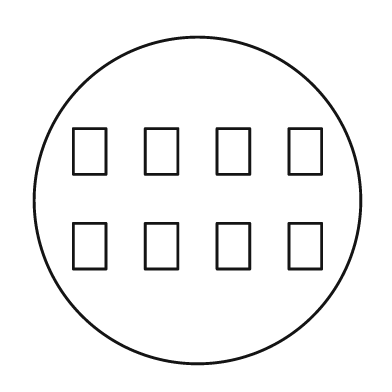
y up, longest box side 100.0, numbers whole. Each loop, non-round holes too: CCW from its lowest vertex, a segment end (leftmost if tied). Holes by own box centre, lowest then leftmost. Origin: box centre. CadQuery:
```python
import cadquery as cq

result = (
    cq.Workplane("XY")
    .moveTo(0.0, 0.0)
    .circle(50.0)
    .moveTo(-38.0, -21.0)
    .lineTo(-28.0, -21.0)
    .lineTo(-28.0, -7.0)
    .lineTo(-38.0, -7.0)
    .close()
    .moveTo(-16.0, -21.0)
    .lineTo(-6.0, -21.0)
    .lineTo(-6.0, -7.0)
    .lineTo(-16.0, -7.0)
    .close()
    .moveTo(6.0, -21.0)
    .lineTo(16.0, -21.0)
    .lineTo(16.0, -7.0)
    .lineTo(6.0, -7.0)
    .close()
    .moveTo(28.0, -21.0)
    .lineTo(38.0, -21.0)
    .lineTo(38.0, -7.0)
    .lineTo(28.0, -7.0)
    .close()
    .moveTo(-38.0, 8.0)
    .lineTo(-28.0, 8.0)
    .lineTo(-28.0, 22.0)
    .lineTo(-38.0, 22.0)
    .close()
    .moveTo(-16.0, 8.0)
    .lineTo(-6.0, 8.0)
    .lineTo(-6.0, 22.0)
    .lineTo(-16.0, 22.0)
    .close()
    .moveTo(6.0, 8.0)
    .lineTo(16.0, 8.0)
    .lineTo(16.0, 22.0)
    .lineTo(6.0, 22.0)
    .close()
    .moveTo(28.0, 8.0)
    .lineTo(38.0, 8.0)
    .lineTo(38.0, 22.0)
    .lineTo(28.0, 22.0)
    .close()
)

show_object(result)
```